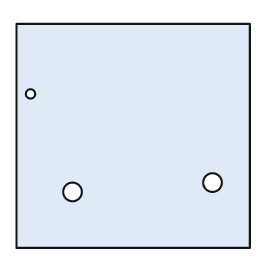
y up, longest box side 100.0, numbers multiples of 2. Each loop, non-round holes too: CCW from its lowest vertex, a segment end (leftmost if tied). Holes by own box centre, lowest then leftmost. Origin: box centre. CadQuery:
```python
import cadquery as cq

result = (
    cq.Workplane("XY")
    .moveTo(-50.0, -48.0)
    .lineTo(50.0, -48.0)
    .lineTo(50.0, 48.0)
    .lineTo(-50.0, 48.0)
    .close()
    .moveTo(-26.0, -24.0)
    .circle(4.0)
    .moveTo(34.0, -20.0)
    .circle(4.0)
    .moveTo(-44.0, 18.0)
    .circle(2.0)
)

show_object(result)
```